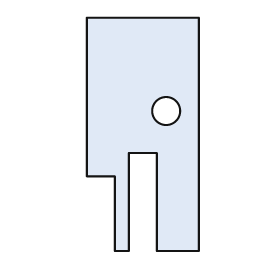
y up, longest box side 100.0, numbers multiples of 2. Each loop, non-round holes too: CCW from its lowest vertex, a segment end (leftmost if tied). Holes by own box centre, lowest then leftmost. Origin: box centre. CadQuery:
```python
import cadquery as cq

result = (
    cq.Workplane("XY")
    .moveTo(-12.0, -50.0)
    .lineTo(-6.0, -50.0)
    .lineTo(-6.0, -8.0)
    .lineTo(6.0, -8.0)
    .lineTo(6.0, -50.0)
    .lineTo(24.0, -50.0)
    .lineTo(24.0, 50.0)
    .lineTo(-24.0, 50.0)
    .lineTo(-24.0, -18.0)
    .lineTo(-12.0, -18.0)
    .close()
    .moveTo(10.0, 10.0)
    .circle(6.0)
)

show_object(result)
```